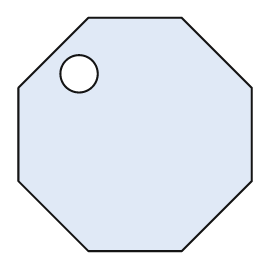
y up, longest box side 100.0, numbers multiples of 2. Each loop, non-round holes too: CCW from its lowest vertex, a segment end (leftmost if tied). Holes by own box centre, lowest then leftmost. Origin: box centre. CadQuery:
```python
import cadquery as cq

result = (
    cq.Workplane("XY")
    .moveTo(-20.0, -50.0)
    .lineTo(20.0, -50.0)
    .lineTo(50.0, -20.0)
    .lineTo(50.0, 20.0)
    .lineTo(20.0, 50.0)
    .lineTo(-20.0, 50.0)
    .lineTo(-50.0, 20.0)
    .lineTo(-50.0, -20.0)
    .close()
    .moveTo(-24.0, 26.0)
    .circle(8.0)
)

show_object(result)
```